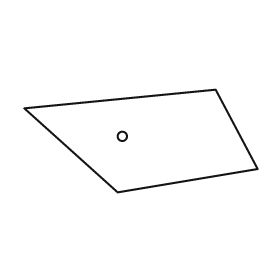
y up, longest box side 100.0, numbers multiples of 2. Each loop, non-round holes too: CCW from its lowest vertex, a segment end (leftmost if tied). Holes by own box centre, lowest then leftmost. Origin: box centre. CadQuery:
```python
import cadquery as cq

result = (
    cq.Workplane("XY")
    .moveTo(-10.0, -22.0)
    .lineTo(50.0, -12.0)
    .lineTo(32.0, 22.0)
    .lineTo(-50.0, 14.0)
    .close()
    .moveTo(-8.0, 2.0)
    .circle(2.0)
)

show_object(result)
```